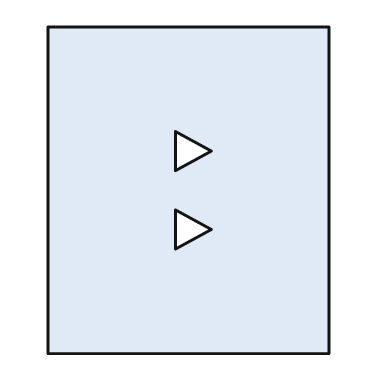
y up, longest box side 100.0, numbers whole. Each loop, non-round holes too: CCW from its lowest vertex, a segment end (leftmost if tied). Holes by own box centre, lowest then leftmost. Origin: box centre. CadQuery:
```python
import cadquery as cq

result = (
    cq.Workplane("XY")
    .moveTo(-43.0, -50.0)
    .lineTo(43.0, -50.0)
    .lineTo(43.0, 50.0)
    .lineTo(-43.0, 50.0)
    .close()
    .moveTo(-4.0, -18.0)
    .lineTo(7.0, -12.0)
    .lineTo(-4.0, -6.0)
    .close()
    .moveTo(-4.0, 6.0)
    .lineTo(7.0, 12.0)
    .lineTo(-4.0, 18.0)
    .close()
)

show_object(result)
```